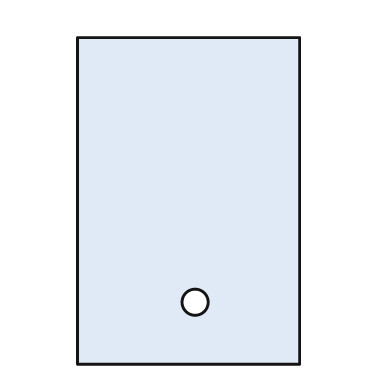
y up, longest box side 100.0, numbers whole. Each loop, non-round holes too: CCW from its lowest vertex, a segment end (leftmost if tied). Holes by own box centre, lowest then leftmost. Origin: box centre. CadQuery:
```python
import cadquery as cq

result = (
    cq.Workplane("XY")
    .moveTo(-34.0, -50.0)
    .lineTo(34.0, -50.0)
    .lineTo(34.0, 50.0)
    .lineTo(-34.0, 50.0)
    .close()
    .moveTo(2.0, -31.0)
    .circle(4.0)
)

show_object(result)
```